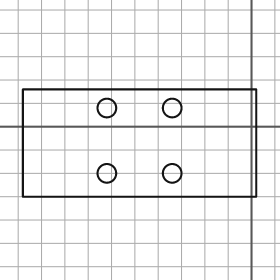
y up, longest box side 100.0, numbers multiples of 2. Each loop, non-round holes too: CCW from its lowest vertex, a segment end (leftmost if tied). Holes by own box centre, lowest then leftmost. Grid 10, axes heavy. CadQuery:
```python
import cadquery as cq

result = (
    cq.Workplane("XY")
    .moveTo(-98.0, -30.0)
    .lineTo(2.0, -30.0)
    .lineTo(2.0, 16.0)
    .lineTo(-98.0, 16.0)
    .close()
    .moveTo(-62.0, -20.0)
    .circle(4.0)
    .moveTo(-34.0, -20.0)
    .circle(4.0)
    .moveTo(-62.0, 8.0)
    .circle(4.0)
    .moveTo(-34.0, 8.0)
    .circle(4.0)
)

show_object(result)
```